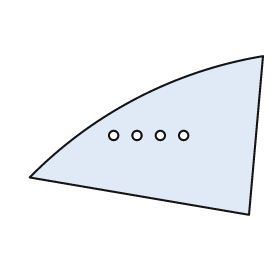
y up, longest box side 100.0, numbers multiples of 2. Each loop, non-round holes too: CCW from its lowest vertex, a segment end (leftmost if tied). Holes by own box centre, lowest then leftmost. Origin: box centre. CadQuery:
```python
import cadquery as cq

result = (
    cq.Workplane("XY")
    .moveTo(44.0, -34.0)
    .lineTo(50.0, 34.0)
    .threePointArc((-4.0, 16.0), (-50.0, -18.0))
    .close()
    .moveTo(-14.0, 0.0)
    .circle(2.0)
    .moveTo(-4.0, 0.0)
    .circle(2.0)
    .moveTo(6.0, 0.0)
    .circle(2.0)
    .moveTo(16.0, 0.0)
    .circle(2.0)
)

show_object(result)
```